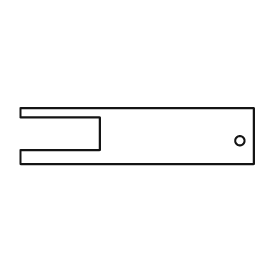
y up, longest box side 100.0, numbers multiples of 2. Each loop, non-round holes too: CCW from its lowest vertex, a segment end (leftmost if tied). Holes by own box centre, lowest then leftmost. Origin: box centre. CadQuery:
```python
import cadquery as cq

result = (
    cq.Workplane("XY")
    .moveTo(-50.0, -12.0)
    .lineTo(50.0, -12.0)
    .lineTo(50.0, 12.0)
    .lineTo(-50.0, 12.0)
    .lineTo(-50.0, 8.0)
    .lineTo(-16.0, 8.0)
    .lineTo(-16.0, -6.0)
    .lineTo(-50.0, -6.0)
    .close()
    .moveTo(44.0, -2.0)
    .circle(2.0)
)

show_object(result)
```